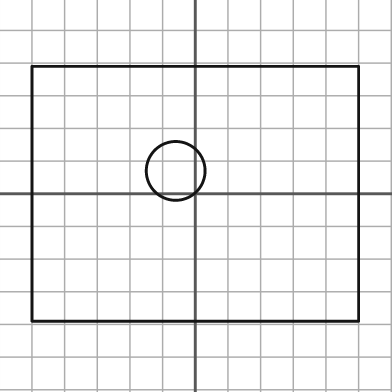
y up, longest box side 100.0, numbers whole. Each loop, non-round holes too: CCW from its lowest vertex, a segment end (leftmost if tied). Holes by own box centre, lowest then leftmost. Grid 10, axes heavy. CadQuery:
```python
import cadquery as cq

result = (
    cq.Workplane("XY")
    .moveTo(-50.0, -39.0)
    .lineTo(50.0, -39.0)
    .lineTo(50.0, 39.0)
    .lineTo(-50.0, 39.0)
    .close()
    .moveTo(-6.0, 7.0)
    .circle(9.0)
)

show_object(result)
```